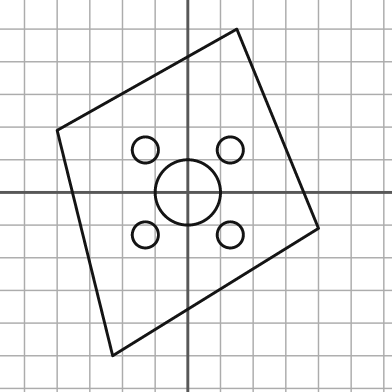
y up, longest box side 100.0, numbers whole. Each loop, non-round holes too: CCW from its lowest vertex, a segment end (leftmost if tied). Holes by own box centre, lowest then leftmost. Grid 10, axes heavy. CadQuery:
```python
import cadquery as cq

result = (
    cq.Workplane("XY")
    .moveTo(-23.0, -50.0)
    .lineTo(40.0, -11.0)
    .lineTo(15.0, 50.0)
    .lineTo(-40.0, 19.0)
    .close()
    .moveTo(-13.0, -13.0)
    .circle(4.0)
    .moveTo(13.0, -13.0)
    .circle(4.0)
    .moveTo(0.0, 0.0)
    .circle(10.0)
    .moveTo(-13.0, 13.0)
    .circle(4.0)
    .moveTo(13.0, 13.0)
    .circle(4.0)
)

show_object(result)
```